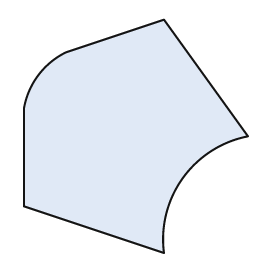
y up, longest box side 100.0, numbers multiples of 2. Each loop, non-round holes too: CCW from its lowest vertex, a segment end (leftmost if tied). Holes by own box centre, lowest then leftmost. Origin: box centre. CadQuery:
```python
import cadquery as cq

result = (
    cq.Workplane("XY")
    .moveTo(12.0, -50.0)
    .threePointArc((20.0, -18.0), (48.0, 0.0))
    .lineTo(12.0, 50.0)
    .lineTo(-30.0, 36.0)
    .threePointArc((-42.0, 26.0), (-48.0, 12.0))
    .lineTo(-48.0, -30.0)
    .close()
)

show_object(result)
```